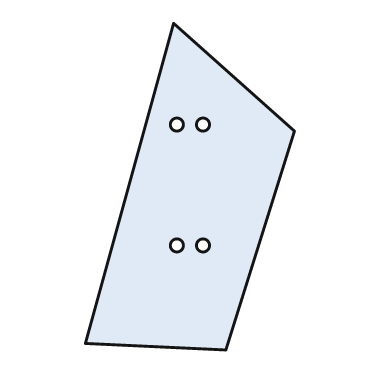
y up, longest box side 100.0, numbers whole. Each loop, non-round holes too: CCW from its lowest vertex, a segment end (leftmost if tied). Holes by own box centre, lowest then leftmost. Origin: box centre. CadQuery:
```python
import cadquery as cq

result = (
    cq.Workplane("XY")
    .moveTo(11.0, -50.0)
    .lineTo(32.0, 17.0)
    .lineTo(-5.0, 50.0)
    .lineTo(-32.0, -48.0)
    .close()
    .moveTo(-4.0, -18.0)
    .circle(2.0)
    .moveTo(4.0, -18.0)
    .circle(2.0)
    .moveTo(-4.0, 19.0)
    .circle(2.0)
    .moveTo(4.0, 19.0)
    .circle(2.0)
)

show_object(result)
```